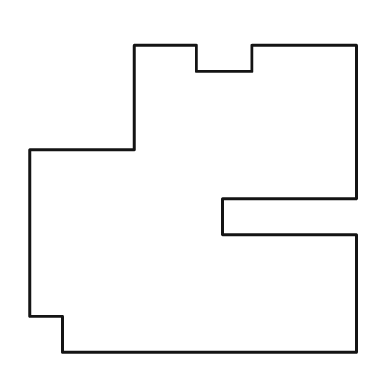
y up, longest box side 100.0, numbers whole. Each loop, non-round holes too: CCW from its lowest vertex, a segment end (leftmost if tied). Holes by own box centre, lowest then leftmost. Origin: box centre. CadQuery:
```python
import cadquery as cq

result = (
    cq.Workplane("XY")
    .moveTo(-40.0, -47.0)
    .lineTo(50.0, -47.0)
    .lineTo(50.0, -11.0)
    .lineTo(9.0, -11.0)
    .lineTo(9.0, 0.0)
    .lineTo(50.0, 0.0)
    .lineTo(50.0, 47.0)
    .lineTo(18.0, 47.0)
    .lineTo(18.0, 39.0)
    .lineTo(1.0, 39.0)
    .lineTo(1.0, 47.0)
    .lineTo(-18.0, 47.0)
    .lineTo(-18.0, 15.0)
    .lineTo(-50.0, 15.0)
    .lineTo(-50.0, -36.0)
    .lineTo(-40.0, -36.0)
    .close()
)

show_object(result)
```